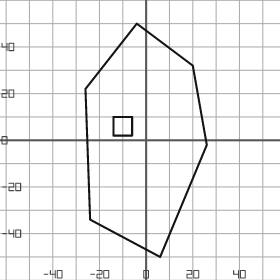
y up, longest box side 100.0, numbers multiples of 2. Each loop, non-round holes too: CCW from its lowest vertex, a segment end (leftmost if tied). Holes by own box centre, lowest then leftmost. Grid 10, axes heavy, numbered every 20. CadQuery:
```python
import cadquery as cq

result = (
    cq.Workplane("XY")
    .moveTo(6.0, -50.0)
    .lineTo(26.0, -2.0)
    .lineTo(20.0, 32.0)
    .lineTo(-4.0, 50.0)
    .lineTo(-26.0, 22.0)
    .lineTo(-24.0, -34.0)
    .close()
    .moveTo(-14.0, 2.0)
    .lineTo(-6.0, 2.0)
    .lineTo(-6.0, 10.0)
    .lineTo(-14.0, 10.0)
    .close()
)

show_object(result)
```